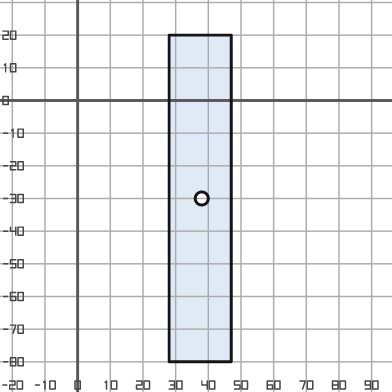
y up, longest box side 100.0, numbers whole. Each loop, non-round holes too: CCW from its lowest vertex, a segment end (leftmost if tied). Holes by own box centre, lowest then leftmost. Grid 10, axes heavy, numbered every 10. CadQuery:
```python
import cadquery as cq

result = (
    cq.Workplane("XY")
    .moveTo(28.0, -80.0)
    .lineTo(47.0, -80.0)
    .lineTo(47.0, 20.0)
    .lineTo(28.0, 20.0)
    .close()
    .moveTo(38.0, -30.0)
    .circle(2.0)
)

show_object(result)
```